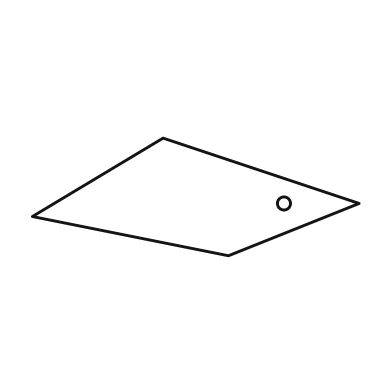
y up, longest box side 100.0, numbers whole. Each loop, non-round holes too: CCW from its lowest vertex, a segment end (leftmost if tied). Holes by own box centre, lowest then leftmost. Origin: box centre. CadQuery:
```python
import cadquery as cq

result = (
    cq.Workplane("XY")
    .moveTo(10.0, -18.0)
    .lineTo(50.0, -2.0)
    .lineTo(-10.0, 18.0)
    .lineTo(-50.0, -6.0)
    .close()
    .moveTo(27.0, -2.0)
    .circle(2.0)
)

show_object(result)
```